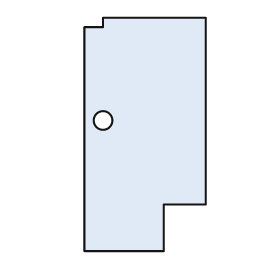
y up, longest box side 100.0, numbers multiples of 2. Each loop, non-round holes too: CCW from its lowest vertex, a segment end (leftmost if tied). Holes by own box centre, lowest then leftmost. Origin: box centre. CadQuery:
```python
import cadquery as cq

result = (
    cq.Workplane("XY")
    .moveTo(-26.0, -50.0)
    .lineTo(8.0, -50.0)
    .lineTo(8.0, -30.0)
    .lineTo(26.0, -30.0)
    .lineTo(26.0, 50.0)
    .lineTo(-18.0, 50.0)
    .lineTo(-18.0, 46.0)
    .lineTo(-26.0, 46.0)
    .close()
    .moveTo(-18.0, 6.0)
    .circle(4.0)
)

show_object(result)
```